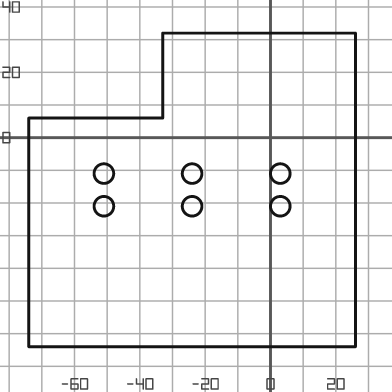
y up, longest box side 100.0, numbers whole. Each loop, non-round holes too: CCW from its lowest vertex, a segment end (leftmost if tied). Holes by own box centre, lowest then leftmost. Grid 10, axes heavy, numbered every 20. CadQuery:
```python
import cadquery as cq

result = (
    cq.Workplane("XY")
    .moveTo(-74.0, -64.0)
    .lineTo(26.0, -64.0)
    .lineTo(26.0, 32.0)
    .lineTo(-33.0, 32.0)
    .lineTo(-33.0, 6.0)
    .lineTo(-74.0, 6.0)
    .close()
    .moveTo(-51.0, -21.0)
    .circle(3.0)
    .moveTo(-24.0, -21.0)
    .circle(3.0)
    .moveTo(3.0, -21.0)
    .circle(3.0)
    .moveTo(-51.0, -11.0)
    .circle(3.0)
    .moveTo(-24.0, -11.0)
    .circle(3.0)
    .moveTo(3.0, -11.0)
    .circle(3.0)
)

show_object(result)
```